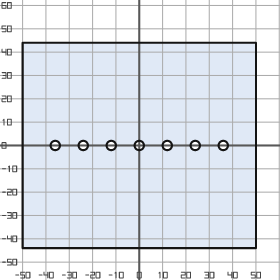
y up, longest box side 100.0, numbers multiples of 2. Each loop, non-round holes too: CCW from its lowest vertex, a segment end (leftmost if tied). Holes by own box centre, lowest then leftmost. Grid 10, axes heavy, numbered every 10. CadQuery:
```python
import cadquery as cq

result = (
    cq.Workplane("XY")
    .moveTo(-50.0, -44.0)
    .lineTo(50.0, -44.0)
    .lineTo(50.0, 44.0)
    .lineTo(-50.0, 44.0)
    .close()
    .moveTo(-36.0, 0.0)
    .circle(2.0)
    .moveTo(-24.0, 0.0)
    .circle(2.0)
    .moveTo(-12.0, 0.0)
    .circle(2.0)
    .moveTo(0.0, 0.0)
    .circle(2.0)
    .moveTo(12.0, 0.0)
    .circle(2.0)
    .moveTo(24.0, 0.0)
    .circle(2.0)
    .moveTo(36.0, 0.0)
    .circle(2.0)
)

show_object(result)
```